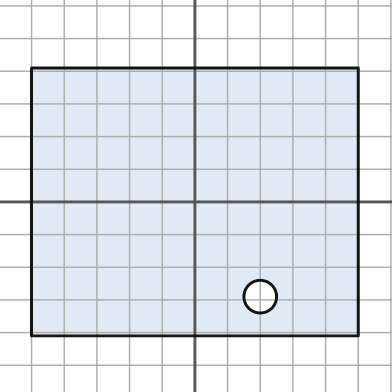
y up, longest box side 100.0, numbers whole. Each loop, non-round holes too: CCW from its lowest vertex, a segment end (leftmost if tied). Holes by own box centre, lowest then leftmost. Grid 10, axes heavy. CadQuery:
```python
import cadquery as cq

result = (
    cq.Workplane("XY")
    .moveTo(-50.0, -41.0)
    .lineTo(50.0, -41.0)
    .lineTo(50.0, 41.0)
    .lineTo(-50.0, 41.0)
    .close()
    .moveTo(20.0, -29.0)
    .circle(5.0)
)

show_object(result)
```